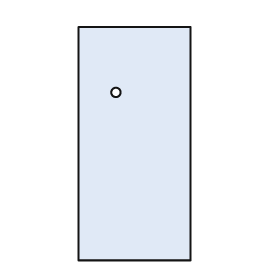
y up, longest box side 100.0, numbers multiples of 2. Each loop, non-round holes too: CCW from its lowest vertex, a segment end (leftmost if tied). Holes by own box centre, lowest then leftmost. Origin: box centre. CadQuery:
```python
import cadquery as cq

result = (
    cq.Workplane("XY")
    .moveTo(-24.0, -50.0)
    .lineTo(24.0, -50.0)
    .lineTo(24.0, 50.0)
    .lineTo(-24.0, 50.0)
    .close()
    .moveTo(-8.0, 22.0)
    .circle(2.0)
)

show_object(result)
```